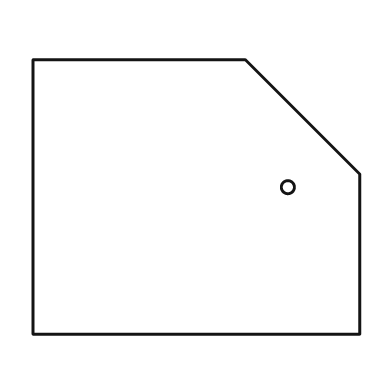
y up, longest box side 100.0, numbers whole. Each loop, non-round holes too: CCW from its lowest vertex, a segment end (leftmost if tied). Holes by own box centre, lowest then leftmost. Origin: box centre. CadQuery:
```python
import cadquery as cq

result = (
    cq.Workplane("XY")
    .moveTo(-50.0, -42.0)
    .lineTo(50.0, -42.0)
    .lineTo(50.0, 7.0)
    .lineTo(15.0, 42.0)
    .lineTo(-50.0, 42.0)
    .close()
    .moveTo(28.0, 3.0)
    .circle(2.0)
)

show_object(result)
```